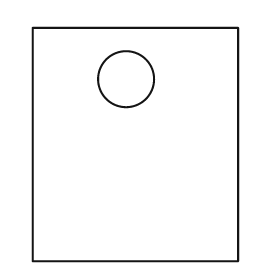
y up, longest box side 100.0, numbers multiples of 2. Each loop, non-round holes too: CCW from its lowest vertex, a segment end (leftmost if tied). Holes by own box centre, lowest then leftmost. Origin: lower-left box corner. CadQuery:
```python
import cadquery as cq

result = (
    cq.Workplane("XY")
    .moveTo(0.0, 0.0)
    .lineTo(88.0, 0.0)
    .lineTo(88.0, 100.0)
    .lineTo(0.0, 100.0)
    .close()
    .moveTo(40.0, 78.0)
    .circle(12.0)
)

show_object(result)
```